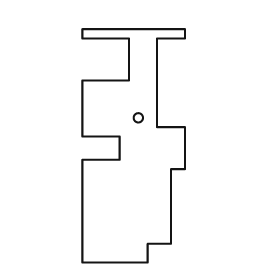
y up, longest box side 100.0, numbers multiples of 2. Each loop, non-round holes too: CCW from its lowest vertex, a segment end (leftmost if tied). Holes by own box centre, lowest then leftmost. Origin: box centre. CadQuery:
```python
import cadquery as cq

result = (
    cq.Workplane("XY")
    .moveTo(-22.0, -50.0)
    .lineTo(6.0, -50.0)
    .lineTo(6.0, -42.0)
    .lineTo(16.0, -42.0)
    .lineTo(16.0, -10.0)
    .lineTo(22.0, -10.0)
    .lineTo(22.0, 8.0)
    .lineTo(10.0, 8.0)
    .lineTo(10.0, 46.0)
    .lineTo(22.0, 46.0)
    .lineTo(22.0, 50.0)
    .lineTo(-22.0, 50.0)
    .lineTo(-22.0, 46.0)
    .lineTo(-2.0, 46.0)
    .lineTo(-2.0, 28.0)
    .lineTo(-22.0, 28.0)
    .lineTo(-22.0, 4.0)
    .lineTo(-6.0, 4.0)
    .lineTo(-6.0, -6.0)
    .lineTo(-22.0, -6.0)
    .close()
    .moveTo(2.0, 12.0)
    .circle(2.0)
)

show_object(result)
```